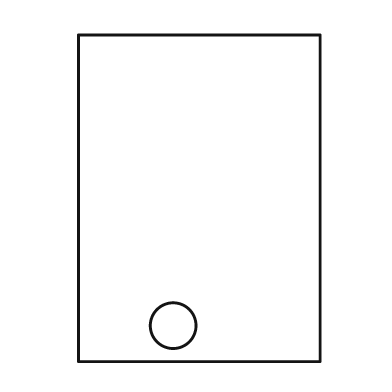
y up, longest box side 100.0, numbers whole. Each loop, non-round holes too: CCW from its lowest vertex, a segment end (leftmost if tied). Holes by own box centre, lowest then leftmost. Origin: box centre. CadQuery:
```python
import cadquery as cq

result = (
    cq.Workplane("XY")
    .moveTo(-37.0, -50.0)
    .lineTo(37.0, -50.0)
    .lineTo(37.0, 50.0)
    .lineTo(-37.0, 50.0)
    .close()
    .moveTo(-8.0, -39.0)
    .circle(7.0)
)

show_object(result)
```